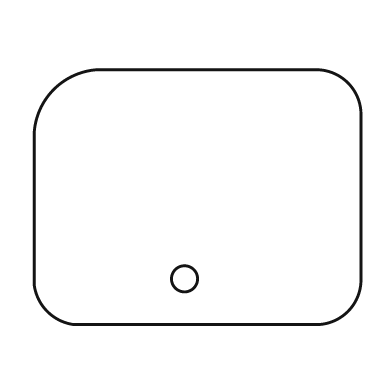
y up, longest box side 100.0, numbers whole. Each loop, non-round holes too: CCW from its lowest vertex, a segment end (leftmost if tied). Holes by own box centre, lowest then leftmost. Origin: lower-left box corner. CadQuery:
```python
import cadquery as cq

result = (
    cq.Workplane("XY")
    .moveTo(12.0, 0.0)
    .lineTo(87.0, 0.0)
    .threePointArc((96.0, 4.0), (100.0, 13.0))
    .lineTo(100.0, 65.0)
    .threePointArc((96.0, 74.0), (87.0, 78.0))
    .lineTo(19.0, 78.0)
    .threePointArc((6.0, 72.0), (0.0, 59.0))
    .lineTo(0.0, 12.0)
    .threePointArc((4.0, 4.0), (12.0, 0.0))
    .close()
    .moveTo(46.0, 14.0)
    .circle(4.0)
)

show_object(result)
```